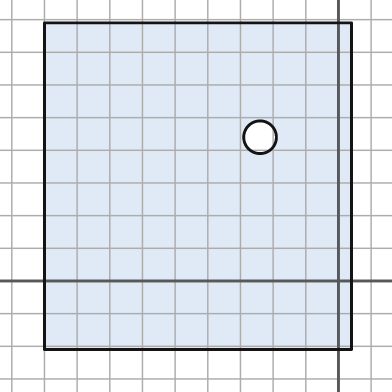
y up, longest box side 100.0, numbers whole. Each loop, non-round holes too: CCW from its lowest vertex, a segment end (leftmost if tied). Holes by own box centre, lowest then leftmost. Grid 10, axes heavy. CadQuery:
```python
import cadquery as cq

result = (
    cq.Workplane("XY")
    .moveTo(-90.0, -21.0)
    .lineTo(4.0, -21.0)
    .lineTo(4.0, 79.0)
    .lineTo(-90.0, 79.0)
    .close()
    .moveTo(-24.0, 44.0)
    .circle(5.0)
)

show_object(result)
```